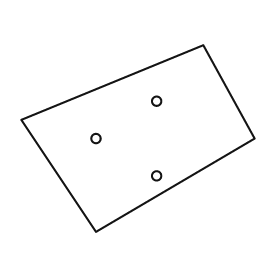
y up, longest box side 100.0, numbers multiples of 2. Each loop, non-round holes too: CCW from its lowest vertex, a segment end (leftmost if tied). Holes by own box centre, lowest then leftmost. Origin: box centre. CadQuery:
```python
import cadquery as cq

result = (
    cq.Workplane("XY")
    .moveTo(-18.0, -40.0)
    .lineTo(50.0, 0.0)
    .lineTo(28.0, 40.0)
    .lineTo(-50.0, 8.0)
    .close()
    .moveTo(8.0, -16.0)
    .circle(2.0)
    .moveTo(-18.0, 0.0)
    .circle(2.0)
    .moveTo(8.0, 16.0)
    .circle(2.0)
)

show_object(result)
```